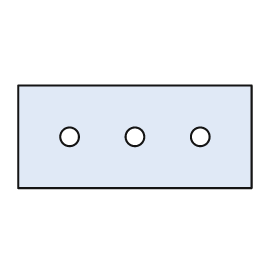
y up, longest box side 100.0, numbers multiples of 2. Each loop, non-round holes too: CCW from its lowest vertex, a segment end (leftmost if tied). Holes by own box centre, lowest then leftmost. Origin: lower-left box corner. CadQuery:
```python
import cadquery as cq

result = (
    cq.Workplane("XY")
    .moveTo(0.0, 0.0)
    .lineTo(100.0, 0.0)
    .lineTo(100.0, 44.0)
    .lineTo(0.0, 44.0)
    .close()
    .moveTo(22.0, 22.0)
    .circle(4.0)
    .moveTo(50.0, 22.0)
    .circle(4.0)
    .moveTo(78.0, 22.0)
    .circle(4.0)
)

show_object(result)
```